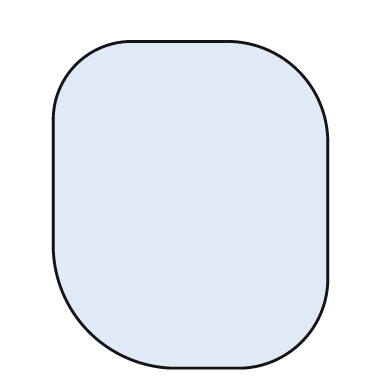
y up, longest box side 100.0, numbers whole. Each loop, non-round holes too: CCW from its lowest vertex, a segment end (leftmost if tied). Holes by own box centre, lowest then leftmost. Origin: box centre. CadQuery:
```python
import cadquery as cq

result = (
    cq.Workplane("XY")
    .moveTo(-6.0, -50.0)
    .lineTo(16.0, -50.0)
    .threePointArc((34.0, -42.0), (42.0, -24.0))
    .lineTo(42.0, 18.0)
    .threePointArc((33.0, 41.0), (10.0, 50.0))
    .lineTo(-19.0, 50.0)
    .threePointArc((-35.0, 43.0), (-42.0, 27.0))
    .lineTo(-42.0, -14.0)
    .threePointArc((-31.0, -39.0), (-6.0, -50.0))
    .close()
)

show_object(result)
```